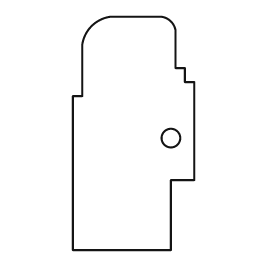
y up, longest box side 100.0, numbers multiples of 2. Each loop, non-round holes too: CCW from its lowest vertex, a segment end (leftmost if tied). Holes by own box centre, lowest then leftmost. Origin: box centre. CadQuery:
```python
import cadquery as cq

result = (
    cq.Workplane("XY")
    .moveTo(-26.0, -50.0)
    .lineTo(16.0, -50.0)
    .lineTo(16.0, -20.0)
    .lineTo(26.0, -20.0)
    .lineTo(26.0, 22.0)
    .lineTo(22.0, 22.0)
    .lineTo(22.0, 28.0)
    .lineTo(18.0, 28.0)
    .lineTo(18.0, 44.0)
    .threePointArc((16.0, 48.0), (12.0, 50.0))
    .lineTo(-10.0, 50.0)
    .threePointArc((-18.0, 46.0), (-22.0, 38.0))
    .lineTo(-22.0, 16.0)
    .lineTo(-26.0, 16.0)
    .close()
    .moveTo(16.0, -2.0)
    .circle(4.0)
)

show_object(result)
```